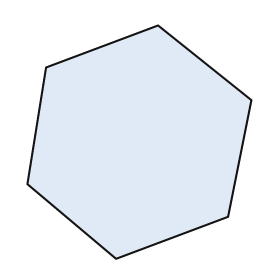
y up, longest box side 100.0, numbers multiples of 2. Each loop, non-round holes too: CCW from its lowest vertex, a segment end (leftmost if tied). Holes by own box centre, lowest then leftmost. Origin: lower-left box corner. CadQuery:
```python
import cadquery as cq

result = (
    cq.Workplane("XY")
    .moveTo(38.0, 0.0)
    .lineTo(86.0, 18.0)
    .lineTo(96.0, 68.0)
    .lineTo(56.0, 100.0)
    .lineTo(8.0, 82.0)
    .lineTo(0.0, 32.0)
    .close()
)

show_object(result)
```